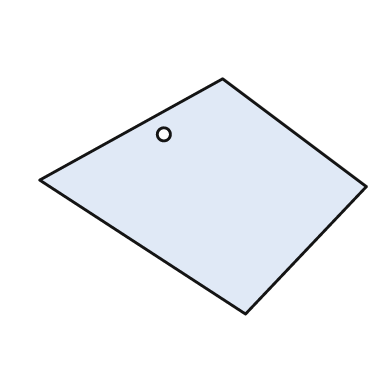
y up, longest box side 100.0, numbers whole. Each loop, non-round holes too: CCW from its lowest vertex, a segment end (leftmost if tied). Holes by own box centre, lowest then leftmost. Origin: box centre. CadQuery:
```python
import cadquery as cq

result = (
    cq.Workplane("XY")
    .moveTo(13.0, -36.0)
    .lineTo(50.0, 3.0)
    .lineTo(6.0, 36.0)
    .lineTo(-50.0, 5.0)
    .close()
    .moveTo(-12.0, 19.0)
    .circle(2.0)
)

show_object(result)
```